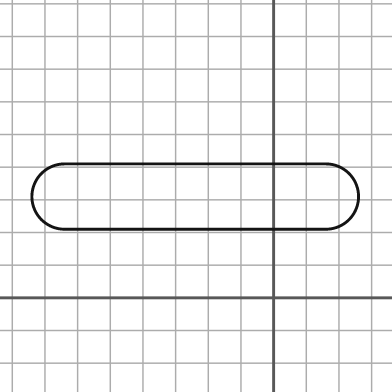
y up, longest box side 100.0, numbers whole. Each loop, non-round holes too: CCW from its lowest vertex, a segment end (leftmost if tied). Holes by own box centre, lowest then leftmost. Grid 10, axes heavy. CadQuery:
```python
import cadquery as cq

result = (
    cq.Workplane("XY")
    .moveTo(-64.0, 21.0)
    .lineTo(16.0, 21.0)
    .threePointArc((26.0, 31.0), (16.0, 41.0))
    .lineTo(-64.0, 41.0)
    .threePointArc((-74.0, 31.0), (-64.0, 21.0))
    .close()
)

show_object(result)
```